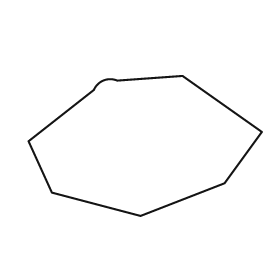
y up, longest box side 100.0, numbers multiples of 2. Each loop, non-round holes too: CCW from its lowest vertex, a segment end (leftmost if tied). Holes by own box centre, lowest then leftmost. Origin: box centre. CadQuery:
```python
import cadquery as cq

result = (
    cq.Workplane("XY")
    .moveTo(-2.0, -30.0)
    .lineTo(34.0, -16.0)
    .lineTo(50.0, 6.0)
    .lineTo(16.0, 30.0)
    .lineTo(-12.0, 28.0)
    .threePointArc((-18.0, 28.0), (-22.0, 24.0))
    .lineTo(-50.0, 2.0)
    .lineTo(-40.0, -20.0)
    .close()
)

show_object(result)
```